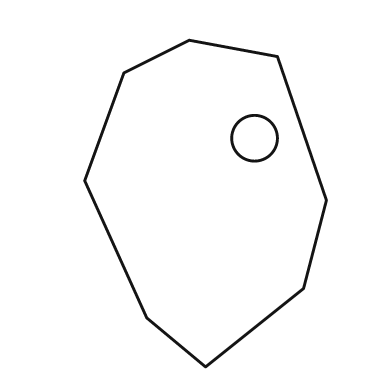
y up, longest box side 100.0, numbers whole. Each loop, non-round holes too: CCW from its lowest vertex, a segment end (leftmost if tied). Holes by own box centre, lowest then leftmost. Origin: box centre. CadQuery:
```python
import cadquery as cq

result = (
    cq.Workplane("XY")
    .moveTo(0.0, -50.0)
    .lineTo(30.0, -26.0)
    .lineTo(37.0, 1.0)
    .lineTo(22.0, 45.0)
    .lineTo(-5.0, 50.0)
    .lineTo(-25.0, 40.0)
    .lineTo(-37.0, 7.0)
    .lineTo(-18.0, -35.0)
    .close()
    .moveTo(15.0, 20.0)
    .circle(7.0)
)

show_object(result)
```